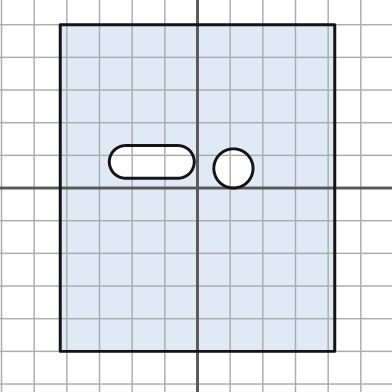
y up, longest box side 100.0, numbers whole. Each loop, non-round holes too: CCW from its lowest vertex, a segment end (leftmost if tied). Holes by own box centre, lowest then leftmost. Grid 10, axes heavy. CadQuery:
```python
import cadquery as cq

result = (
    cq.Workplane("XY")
    .moveTo(-42.0, -50.0)
    .lineTo(42.0, -50.0)
    .lineTo(42.0, 50.0)
    .lineTo(-42.0, 50.0)
    .close()
    .moveTo(11.0, 6.0)
    .circle(6.0)
    .moveTo(-22.0, 3.0)
    .lineTo(-6.0, 3.0)
    .threePointArc((-1.0, 8.0), (-6.0, 13.0))
    .lineTo(-22.0, 13.0)
    .threePointArc((-27.0, 8.0), (-22.0, 3.0))
    .close()
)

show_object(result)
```